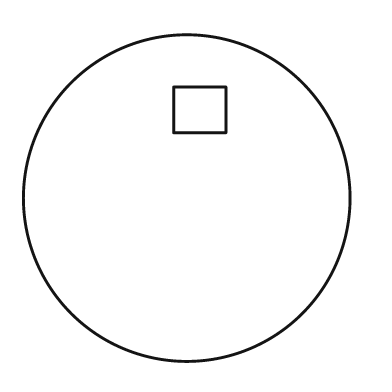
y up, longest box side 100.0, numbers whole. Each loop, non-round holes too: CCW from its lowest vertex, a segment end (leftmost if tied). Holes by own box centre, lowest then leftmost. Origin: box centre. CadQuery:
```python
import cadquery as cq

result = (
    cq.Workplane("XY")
    .moveTo(0.0, 0.0)
    .circle(50.0)
    .moveTo(-4.0, 20.0)
    .lineTo(12.0, 20.0)
    .lineTo(12.0, 34.0)
    .lineTo(-4.0, 34.0)
    .close()
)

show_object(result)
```